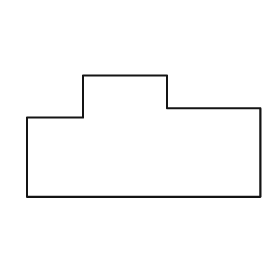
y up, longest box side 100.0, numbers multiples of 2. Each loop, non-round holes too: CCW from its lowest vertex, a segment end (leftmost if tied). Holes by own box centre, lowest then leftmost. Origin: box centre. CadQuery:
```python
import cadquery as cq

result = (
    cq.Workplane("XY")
    .moveTo(-50.0, -26.0)
    .lineTo(50.0, -26.0)
    .lineTo(50.0, 12.0)
    .lineTo(10.0, 12.0)
    .lineTo(10.0, 26.0)
    .lineTo(-26.0, 26.0)
    .lineTo(-26.0, 8.0)
    .lineTo(-50.0, 8.0)
    .close()
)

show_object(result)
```